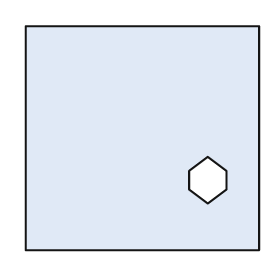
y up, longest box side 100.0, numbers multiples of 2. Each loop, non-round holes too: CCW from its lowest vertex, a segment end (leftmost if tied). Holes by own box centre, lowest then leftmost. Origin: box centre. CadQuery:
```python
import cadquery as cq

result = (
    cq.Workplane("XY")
    .moveTo(-50.0, -48.0)
    .lineTo(50.0, -48.0)
    .lineTo(50.0, 48.0)
    .lineTo(-50.0, 48.0)
    .close()
    .moveTo(28.0, -28.0)
    .lineTo(36.0, -22.0)
    .lineTo(36.0, -14.0)
    .lineTo(28.0, -8.0)
    .lineTo(20.0, -14.0)
    .lineTo(20.0, -22.0)
    .close()
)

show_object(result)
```